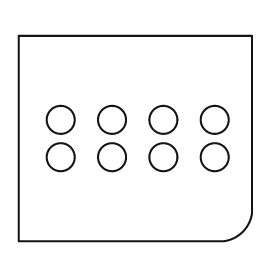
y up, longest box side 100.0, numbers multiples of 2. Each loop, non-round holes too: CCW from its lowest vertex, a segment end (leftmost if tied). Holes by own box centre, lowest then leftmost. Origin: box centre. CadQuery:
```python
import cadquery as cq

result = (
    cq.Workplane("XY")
    .moveTo(-50.0, -44.0)
    .lineTo(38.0, -44.0)
    .threePointArc((46.0, -40.0), (50.0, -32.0))
    .lineTo(50.0, 44.0)
    .lineTo(-50.0, 44.0)
    .close()
    .moveTo(-32.0, -8.0)
    .circle(6.0)
    .moveTo(-10.0, -8.0)
    .circle(6.0)
    .moveTo(12.0, -8.0)
    .circle(6.0)
    .moveTo(34.0, -8.0)
    .circle(6.0)
    .moveTo(-32.0, 8.0)
    .circle(6.0)
    .moveTo(-10.0, 8.0)
    .circle(6.0)
    .moveTo(12.0, 8.0)
    .circle(6.0)
    .moveTo(34.0, 8.0)
    .circle(6.0)
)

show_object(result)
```